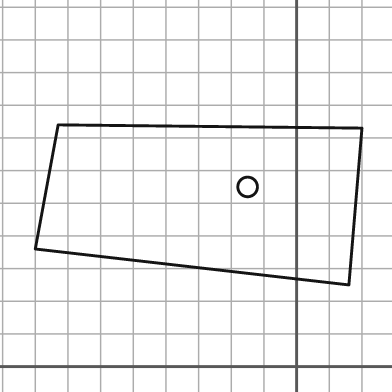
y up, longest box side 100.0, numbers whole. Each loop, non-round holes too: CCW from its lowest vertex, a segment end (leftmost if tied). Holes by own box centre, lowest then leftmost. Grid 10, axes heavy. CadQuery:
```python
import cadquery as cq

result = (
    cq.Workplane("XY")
    .moveTo(16.0, 25.0)
    .lineTo(20.0, 73.0)
    .lineTo(-73.0, 74.0)
    .lineTo(-80.0, 36.0)
    .close()
    .moveTo(-15.0, 55.0)
    .circle(3.0)
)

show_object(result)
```